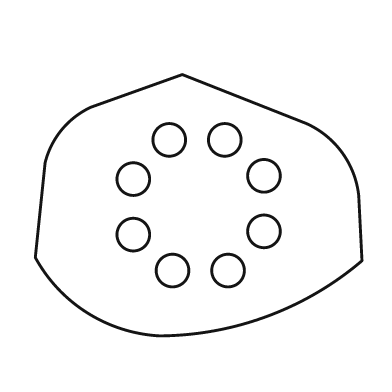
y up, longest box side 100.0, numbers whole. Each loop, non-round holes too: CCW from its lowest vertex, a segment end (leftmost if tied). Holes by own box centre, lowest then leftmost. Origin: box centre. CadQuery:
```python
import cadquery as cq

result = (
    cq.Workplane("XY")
    .moveTo(-12.0, -40.0)
    .threePointArc((21.0, -34.0), (50.0, -17.0))
    .lineTo(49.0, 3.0)
    .threePointArc((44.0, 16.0), (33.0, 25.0))
    .lineTo(-5.0, 40.0)
    .lineTo(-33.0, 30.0)
    .threePointArc((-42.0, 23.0), (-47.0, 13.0))
    .lineTo(-50.0, -16.0)
    .threePointArc((-34.0, -33.0), (-12.0, -40.0))
    .close()
    .moveTo(-8.0, -20.0)
    .circle(5.0)
    .moveTo(9.0, -20.0)
    .circle(5.0)
    .moveTo(-20.0, -9.0)
    .circle(5.0)
    .moveTo(20.0, -8.0)
    .circle(5.0)
    .moveTo(-20.0, 8.0)
    .circle(5.0)
    .moveTo(20.0, 9.0)
    .circle(5.0)
    .moveTo(-9.0, 20.0)
    .circle(5.0)
    .moveTo(8.0, 20.0)
    .circle(5.0)
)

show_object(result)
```